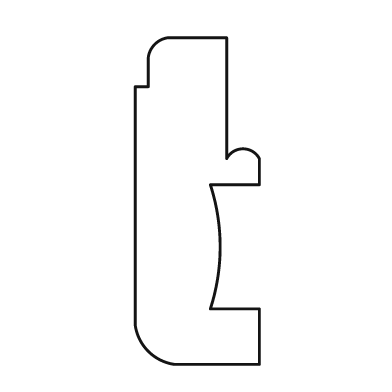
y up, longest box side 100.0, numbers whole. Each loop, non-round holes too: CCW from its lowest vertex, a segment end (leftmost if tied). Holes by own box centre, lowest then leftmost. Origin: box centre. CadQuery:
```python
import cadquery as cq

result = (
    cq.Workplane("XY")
    .moveTo(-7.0, -50.0)
    .lineTo(19.0, -50.0)
    .lineTo(19.0, -33.0)
    .lineTo(4.0, -33.0)
    .threePointArc((7.0, -14.0), (4.0, 5.0))
    .lineTo(19.0, 5.0)
    .lineTo(19.0, 13.0)
    .threePointArc((14.0, 16.0), (9.0, 13.0))
    .lineTo(9.0, 50.0)
    .lineTo(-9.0, 50.0)
    .threePointArc((-13.0, 48.0), (-15.0, 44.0))
    .lineTo(-15.0, 35.0)
    .lineTo(-19.0, 35.0)
    .lineTo(-19.0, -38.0)
    .threePointArc((-15.0, -46.0), (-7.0, -50.0))
    .close()
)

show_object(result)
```